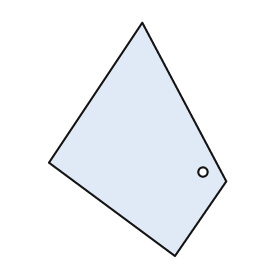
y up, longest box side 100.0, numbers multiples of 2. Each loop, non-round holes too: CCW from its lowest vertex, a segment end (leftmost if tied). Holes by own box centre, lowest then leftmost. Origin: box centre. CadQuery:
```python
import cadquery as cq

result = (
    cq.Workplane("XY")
    .moveTo(16.0, -50.0)
    .lineTo(38.0, -18.0)
    .lineTo(2.0, 50.0)
    .lineTo(-38.0, -10.0)
    .close()
    .moveTo(28.0, -14.0)
    .circle(2.0)
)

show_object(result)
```